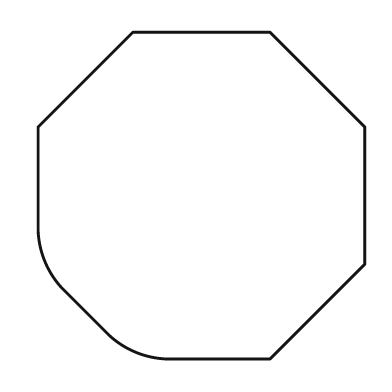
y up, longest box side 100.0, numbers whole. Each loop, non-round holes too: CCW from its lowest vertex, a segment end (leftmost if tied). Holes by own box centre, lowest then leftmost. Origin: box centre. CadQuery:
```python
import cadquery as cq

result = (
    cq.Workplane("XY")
    .moveTo(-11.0, -50.0)
    .lineTo(21.0, -50.0)
    .lineTo(50.0, -21.0)
    .lineTo(50.0, 21.0)
    .lineTo(21.0, 50.0)
    .lineTo(-21.0, 50.0)
    .lineTo(-50.0, 21.0)
    .lineTo(-50.0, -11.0)
    .threePointArc((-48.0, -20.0), (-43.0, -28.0))
    .lineTo(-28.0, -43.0)
    .threePointArc((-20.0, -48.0), (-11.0, -50.0))
    .close()
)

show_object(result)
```